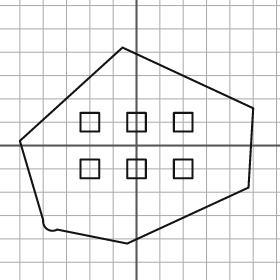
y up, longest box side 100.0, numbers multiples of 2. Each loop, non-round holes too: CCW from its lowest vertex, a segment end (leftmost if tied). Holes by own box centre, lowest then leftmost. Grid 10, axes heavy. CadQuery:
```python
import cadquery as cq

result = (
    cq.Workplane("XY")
    .moveTo(-4.0, -42.0)
    .lineTo(48.0, -18.0)
    .lineTo(50.0, 16.0)
    .lineTo(-6.0, 42.0)
    .lineTo(-50.0, 2.0)
    .lineTo(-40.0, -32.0)
    .threePointArc((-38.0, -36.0), (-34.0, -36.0))
    .close()
    .moveTo(-24.0, -14.0)
    .lineTo(-16.0, -14.0)
    .lineTo(-16.0, -6.0)
    .lineTo(-24.0, -6.0)
    .close()
    .moveTo(-4.0, -14.0)
    .lineTo(4.0, -14.0)
    .lineTo(4.0, -6.0)
    .lineTo(-4.0, -6.0)
    .close()
    .moveTo(16.0, -14.0)
    .lineTo(24.0, -14.0)
    .lineTo(24.0, -6.0)
    .lineTo(16.0, -6.0)
    .close()
    .moveTo(-24.0, 6.0)
    .lineTo(-16.0, 6.0)
    .lineTo(-16.0, 14.0)
    .lineTo(-24.0, 14.0)
    .close()
    .moveTo(-4.0, 6.0)
    .lineTo(4.0, 6.0)
    .lineTo(4.0, 14.0)
    .lineTo(-4.0, 14.0)
    .close()
    .moveTo(16.0, 6.0)
    .lineTo(24.0, 6.0)
    .lineTo(24.0, 14.0)
    .lineTo(16.0, 14.0)
    .close()
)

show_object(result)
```